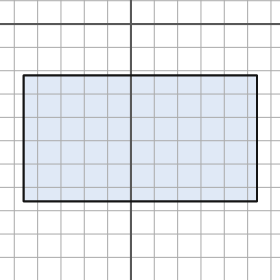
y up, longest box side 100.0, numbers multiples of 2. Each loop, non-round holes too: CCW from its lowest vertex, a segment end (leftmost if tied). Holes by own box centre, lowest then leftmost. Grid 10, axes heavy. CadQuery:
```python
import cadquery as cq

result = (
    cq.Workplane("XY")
    .moveTo(-46.0, -76.0)
    .lineTo(54.0, -76.0)
    .lineTo(54.0, -22.0)
    .lineTo(-46.0, -22.0)
    .close()
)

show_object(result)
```